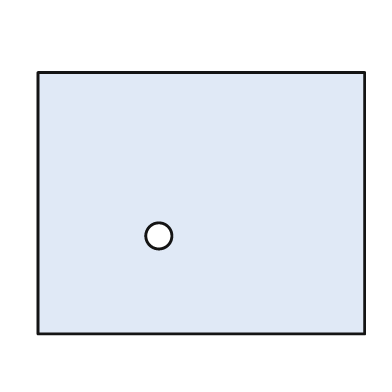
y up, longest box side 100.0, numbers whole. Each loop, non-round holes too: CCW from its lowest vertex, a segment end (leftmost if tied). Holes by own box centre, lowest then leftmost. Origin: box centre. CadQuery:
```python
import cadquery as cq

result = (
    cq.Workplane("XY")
    .moveTo(-50.0, -40.0)
    .lineTo(50.0, -40.0)
    .lineTo(50.0, 40.0)
    .lineTo(-50.0, 40.0)
    .close()
    .moveTo(-13.0, -10.0)
    .circle(4.0)
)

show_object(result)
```